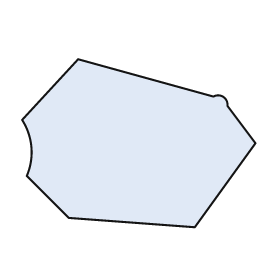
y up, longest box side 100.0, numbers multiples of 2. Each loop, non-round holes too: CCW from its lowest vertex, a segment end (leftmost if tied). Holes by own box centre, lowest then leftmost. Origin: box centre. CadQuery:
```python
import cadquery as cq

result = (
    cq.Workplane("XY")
    .moveTo(24.0, -36.0)
    .lineTo(50.0, 0.0)
    .lineTo(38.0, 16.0)
    .threePointArc((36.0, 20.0), (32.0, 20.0))
    .lineTo(-26.0, 36.0)
    .lineTo(-50.0, 10.0)
    .threePointArc((-46.0, -2.0), (-48.0, -14.0))
    .lineTo(-30.0, -32.0)
    .close()
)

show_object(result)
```